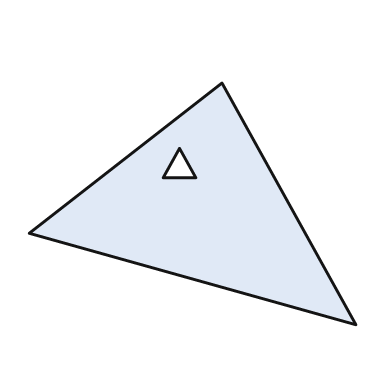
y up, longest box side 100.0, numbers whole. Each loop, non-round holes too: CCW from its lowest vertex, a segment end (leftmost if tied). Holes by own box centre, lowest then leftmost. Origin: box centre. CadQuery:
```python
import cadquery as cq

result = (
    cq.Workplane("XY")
    .moveTo(50.0, -37.0)
    .lineTo(9.0, 37.0)
    .lineTo(-50.0, -9.0)
    .close()
    .moveTo(-9.0, 8.0)
    .lineTo(1.0, 8.0)
    .lineTo(-4.0, 17.0)
    .close()
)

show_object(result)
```